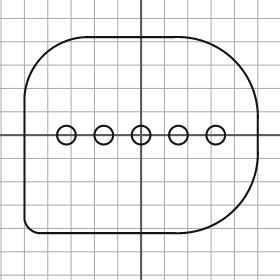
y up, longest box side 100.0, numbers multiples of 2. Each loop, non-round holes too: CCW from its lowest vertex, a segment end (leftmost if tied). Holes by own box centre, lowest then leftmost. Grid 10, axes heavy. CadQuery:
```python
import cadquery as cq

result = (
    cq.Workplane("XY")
    .moveTo(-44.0, -42.0)
    .lineTo(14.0, -42.0)
    .threePointArc((40.0, -32.0), (50.0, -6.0))
    .lineTo(50.0, 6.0)
    .threePointArc((40.0, 32.0), (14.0, 42.0))
    .lineTo(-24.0, 42.0)
    .threePointArc((-42.0, 34.0), (-50.0, 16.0))
    .lineTo(-50.0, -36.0)
    .threePointArc((-48.0, -40.0), (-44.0, -42.0))
    .close()
    .moveTo(-32.0, 0.0)
    .circle(4.0)
    .moveTo(-16.0, 0.0)
    .circle(4.0)
    .moveTo(0.0, 0.0)
    .circle(4.0)
    .moveTo(16.0, 0.0)
    .circle(4.0)
    .moveTo(32.0, 0.0)
    .circle(4.0)
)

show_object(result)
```